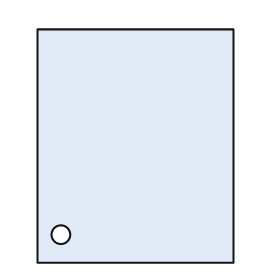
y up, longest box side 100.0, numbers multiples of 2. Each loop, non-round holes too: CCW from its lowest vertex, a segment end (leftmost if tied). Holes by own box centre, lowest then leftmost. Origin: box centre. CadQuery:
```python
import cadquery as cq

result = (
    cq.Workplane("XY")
    .moveTo(-42.0, -50.0)
    .lineTo(42.0, -50.0)
    .lineTo(42.0, 50.0)
    .lineTo(-42.0, 50.0)
    .close()
    .moveTo(-32.0, -38.0)
    .circle(4.0)
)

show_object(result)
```